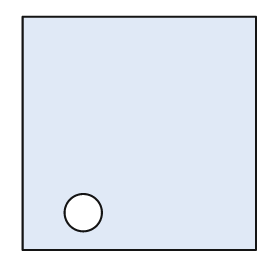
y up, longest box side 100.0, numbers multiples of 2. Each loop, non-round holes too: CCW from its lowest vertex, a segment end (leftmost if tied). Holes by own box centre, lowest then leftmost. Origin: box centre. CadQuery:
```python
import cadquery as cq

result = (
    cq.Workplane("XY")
    .moveTo(-50.0, -50.0)
    .lineTo(50.0, -50.0)
    .lineTo(50.0, 50.0)
    .lineTo(-50.0, 50.0)
    .close()
    .moveTo(-24.0, -34.0)
    .circle(8.0)
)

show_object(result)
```